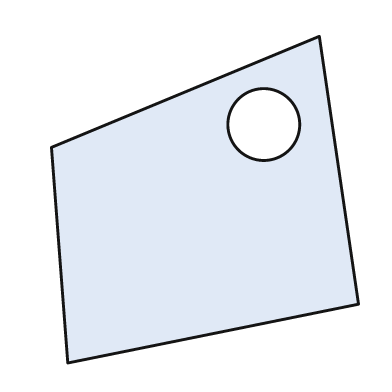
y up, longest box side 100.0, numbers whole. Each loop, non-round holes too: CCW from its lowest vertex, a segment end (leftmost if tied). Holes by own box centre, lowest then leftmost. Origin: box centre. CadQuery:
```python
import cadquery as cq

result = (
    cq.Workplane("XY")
    .moveTo(-42.0, -50.0)
    .lineTo(47.0, -32.0)
    .lineTo(35.0, 50.0)
    .lineTo(-47.0, 16.0)
    .close()
    .moveTo(18.0, 23.0)
    .circle(11.0)
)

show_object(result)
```